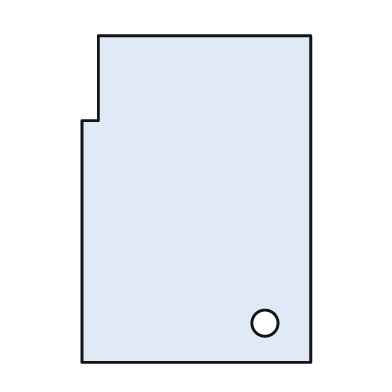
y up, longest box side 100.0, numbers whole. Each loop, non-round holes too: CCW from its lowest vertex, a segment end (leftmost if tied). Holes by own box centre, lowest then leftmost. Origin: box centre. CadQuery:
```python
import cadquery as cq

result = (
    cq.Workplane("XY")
    .moveTo(-35.0, -50.0)
    .lineTo(35.0, -50.0)
    .lineTo(35.0, 50.0)
    .lineTo(-30.0, 50.0)
    .lineTo(-30.0, 24.0)
    .lineTo(-35.0, 24.0)
    .close()
    .moveTo(21.0, -38.0)
    .circle(4.0)
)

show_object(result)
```